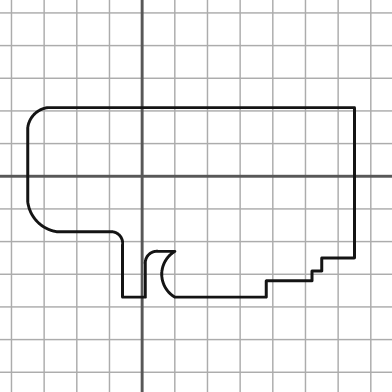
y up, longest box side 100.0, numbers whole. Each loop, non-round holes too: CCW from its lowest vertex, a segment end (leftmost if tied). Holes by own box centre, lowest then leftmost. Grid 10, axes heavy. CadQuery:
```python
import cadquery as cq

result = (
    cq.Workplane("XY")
    .moveTo(-6.0, -37.0)
    .lineTo(1.0, -37.0)
    .lineTo(1.0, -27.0)
    .threePointArc((2.0, -24.0), (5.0, -23.0))
    .lineTo(10.0, -23.0)
    .threePointArc((6.0, -30.0), (10.0, -37.0))
    .lineTo(38.0, -37.0)
    .lineTo(38.0, -32.0)
    .lineTo(52.0, -32.0)
    .lineTo(52.0, -29.0)
    .lineTo(55.0, -29.0)
    .lineTo(55.0, -25.0)
    .lineTo(65.0, -25.0)
    .lineTo(65.0, 21.0)
    .lineTo(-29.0, 21.0)
    .threePointArc((-33.0, 19.0), (-35.0, 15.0))
    .lineTo(-35.0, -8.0)
    .threePointArc((-32.0, -14.0), (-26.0, -17.0))
    .lineTo(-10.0, -17.0)
    .threePointArc((-7.0, -18.0), (-6.0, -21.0))
    .close()
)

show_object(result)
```